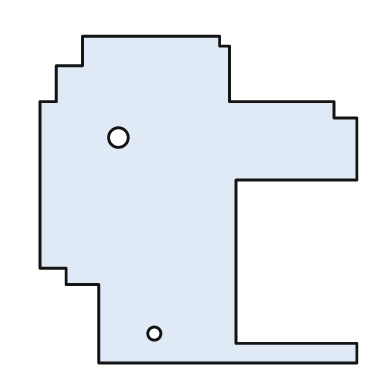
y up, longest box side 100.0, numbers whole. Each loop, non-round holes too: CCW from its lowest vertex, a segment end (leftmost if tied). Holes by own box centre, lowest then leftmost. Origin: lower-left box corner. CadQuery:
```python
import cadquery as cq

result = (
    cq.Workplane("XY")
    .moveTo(18.0, 0.0)
    .lineTo(97.0, 0.0)
    .lineTo(97.0, 6.0)
    .lineTo(60.0, 6.0)
    .lineTo(60.0, 56.0)
    .lineTo(97.0, 56.0)
    .lineTo(97.0, 75.0)
    .lineTo(90.0, 75.0)
    .lineTo(90.0, 80.0)
    .lineTo(58.0, 80.0)
    .lineTo(58.0, 97.0)
    .lineTo(55.0, 97.0)
    .lineTo(55.0, 100.0)
    .lineTo(13.0, 100.0)
    .lineTo(13.0, 91.0)
    .lineTo(5.0, 91.0)
    .lineTo(5.0, 80.0)
    .lineTo(0.0, 80.0)
    .lineTo(0.0, 29.0)
    .lineTo(8.0, 29.0)
    .lineTo(8.0, 24.0)
    .lineTo(18.0, 24.0)
    .close()
    .moveTo(35.0, 9.0)
    .circle(2.0)
    .moveTo(24.0, 69.0)
    .circle(3.0)
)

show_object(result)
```